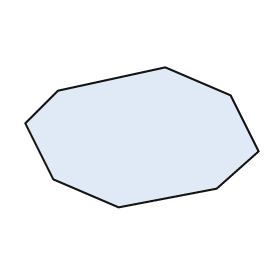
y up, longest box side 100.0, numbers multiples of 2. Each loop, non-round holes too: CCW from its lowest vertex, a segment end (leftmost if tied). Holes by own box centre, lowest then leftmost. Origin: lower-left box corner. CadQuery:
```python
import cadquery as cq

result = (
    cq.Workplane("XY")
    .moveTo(40.0, 0.0)
    .lineTo(82.0, 8.0)
    .lineTo(100.0, 24.0)
    .lineTo(88.0, 48.0)
    .lineTo(60.0, 60.0)
    .lineTo(14.0, 50.0)
    .lineTo(0.0, 36.0)
    .lineTo(12.0, 12.0)
    .close()
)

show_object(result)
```